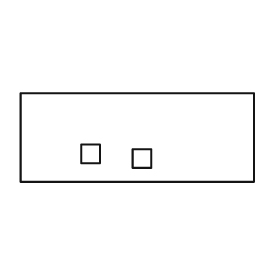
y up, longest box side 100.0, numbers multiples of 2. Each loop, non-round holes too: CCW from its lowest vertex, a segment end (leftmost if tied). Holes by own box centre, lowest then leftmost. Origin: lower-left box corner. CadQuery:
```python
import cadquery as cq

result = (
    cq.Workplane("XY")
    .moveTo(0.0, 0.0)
    .lineTo(100.0, 0.0)
    .lineTo(100.0, 38.0)
    .lineTo(0.0, 38.0)
    .close()
    .moveTo(48.0, 6.0)
    .lineTo(56.0, 6.0)
    .lineTo(56.0, 14.0)
    .lineTo(48.0, 14.0)
    .close()
    .moveTo(26.0, 8.0)
    .lineTo(34.0, 8.0)
    .lineTo(34.0, 16.0)
    .lineTo(26.0, 16.0)
    .close()
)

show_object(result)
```